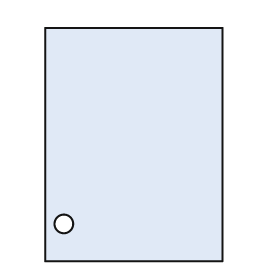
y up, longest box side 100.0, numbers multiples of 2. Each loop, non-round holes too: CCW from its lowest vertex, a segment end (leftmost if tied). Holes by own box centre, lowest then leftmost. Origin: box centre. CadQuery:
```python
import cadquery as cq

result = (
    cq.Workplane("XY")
    .moveTo(-38.0, -50.0)
    .lineTo(38.0, -50.0)
    .lineTo(38.0, 50.0)
    .lineTo(-38.0, 50.0)
    .close()
    .moveTo(-30.0, -34.0)
    .circle(4.0)
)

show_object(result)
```